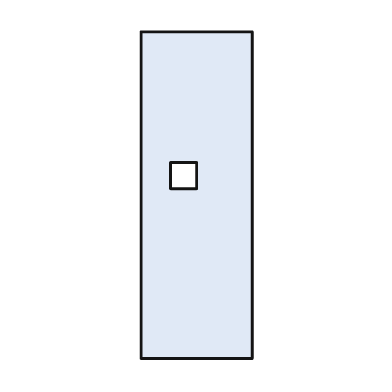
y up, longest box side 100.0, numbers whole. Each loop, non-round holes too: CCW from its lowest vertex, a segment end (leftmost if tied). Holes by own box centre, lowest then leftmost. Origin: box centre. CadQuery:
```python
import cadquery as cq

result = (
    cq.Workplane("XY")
    .moveTo(-17.0, -50.0)
    .lineTo(17.0, -50.0)
    .lineTo(17.0, 50.0)
    .lineTo(-17.0, 50.0)
    .close()
    .moveTo(-8.0, 2.0)
    .lineTo(0.0, 2.0)
    .lineTo(0.0, 10.0)
    .lineTo(-8.0, 10.0)
    .close()
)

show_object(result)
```